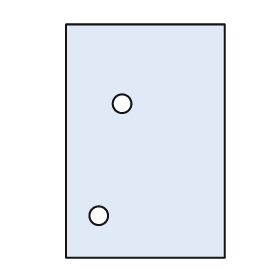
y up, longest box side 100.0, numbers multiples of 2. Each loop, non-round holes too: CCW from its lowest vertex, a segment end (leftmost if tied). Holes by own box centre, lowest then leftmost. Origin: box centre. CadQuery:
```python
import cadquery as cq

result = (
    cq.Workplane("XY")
    .moveTo(-34.0, -50.0)
    .lineTo(34.0, -50.0)
    .lineTo(34.0, 50.0)
    .lineTo(-34.0, 50.0)
    .close()
    .moveTo(-20.0, -32.0)
    .circle(4.0)
    .moveTo(-10.0, 16.0)
    .circle(4.0)
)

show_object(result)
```